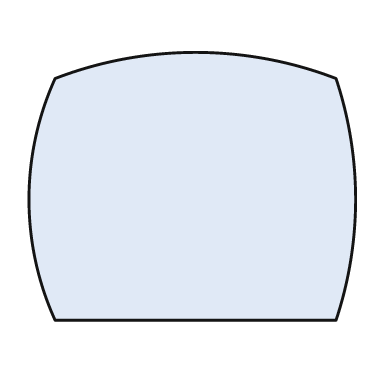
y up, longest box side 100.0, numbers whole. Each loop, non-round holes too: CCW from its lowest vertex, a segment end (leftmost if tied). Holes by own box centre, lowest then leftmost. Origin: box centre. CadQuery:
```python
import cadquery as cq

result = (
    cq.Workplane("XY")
    .moveTo(-42.0, -41.0)
    .lineTo(44.0, -41.0)
    .threePointArc((50.0, -4.0), (44.0, 33.0))
    .threePointArc((1.0, 41.0), (-42.0, 33.0))
    .threePointArc((-50.0, -4.0), (-42.0, -41.0))
    .close()
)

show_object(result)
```